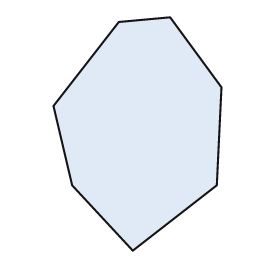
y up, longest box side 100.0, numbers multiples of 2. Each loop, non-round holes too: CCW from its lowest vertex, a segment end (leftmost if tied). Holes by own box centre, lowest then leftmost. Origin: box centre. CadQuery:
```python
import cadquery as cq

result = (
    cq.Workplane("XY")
    .moveTo(-2.0, -50.0)
    .lineTo(34.0, -22.0)
    .lineTo(36.0, 20.0)
    .lineTo(14.0, 50.0)
    .lineTo(-8.0, 48.0)
    .lineTo(-36.0, 12.0)
    .lineTo(-28.0, -22.0)
    .close()
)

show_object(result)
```